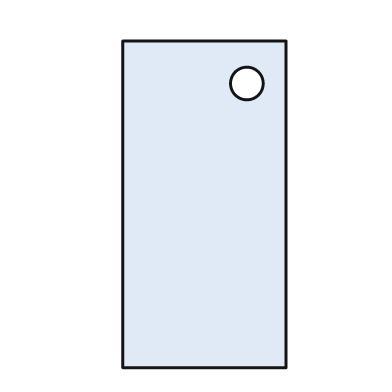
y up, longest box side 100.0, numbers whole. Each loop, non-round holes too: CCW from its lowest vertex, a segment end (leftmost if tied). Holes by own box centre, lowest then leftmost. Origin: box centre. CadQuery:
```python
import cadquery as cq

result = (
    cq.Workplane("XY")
    .moveTo(-25.0, -50.0)
    .lineTo(25.0, -50.0)
    .lineTo(25.0, 50.0)
    .lineTo(-25.0, 50.0)
    .close()
    .moveTo(13.0, 37.0)
    .circle(5.0)
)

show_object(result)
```